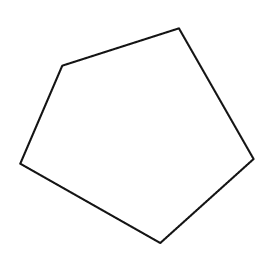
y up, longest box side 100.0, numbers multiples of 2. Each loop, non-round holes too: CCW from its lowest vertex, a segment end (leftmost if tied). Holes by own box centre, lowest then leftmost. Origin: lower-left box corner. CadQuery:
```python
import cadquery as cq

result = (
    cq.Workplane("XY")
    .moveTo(60.0, 0.0)
    .lineTo(100.0, 36.0)
    .lineTo(68.0, 92.0)
    .lineTo(18.0, 76.0)
    .lineTo(0.0, 34.0)
    .close()
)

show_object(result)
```